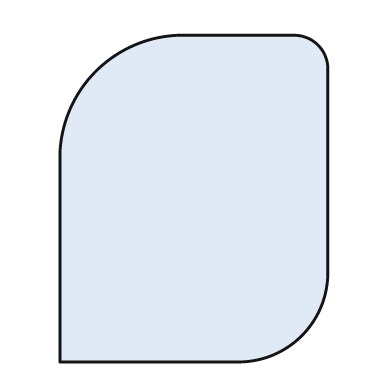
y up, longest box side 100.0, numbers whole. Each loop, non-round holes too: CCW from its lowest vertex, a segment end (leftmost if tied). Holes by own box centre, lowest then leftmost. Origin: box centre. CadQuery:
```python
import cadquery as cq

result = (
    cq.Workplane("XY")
    .moveTo(-41.0, -50.0)
    .lineTo(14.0, -50.0)
    .threePointArc((33.0, -42.0), (41.0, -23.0))
    .lineTo(41.0, 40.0)
    .threePointArc((38.0, 47.0), (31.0, 50.0))
    .lineTo(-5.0, 50.0)
    .threePointArc((-30.0, 39.0), (-41.0, 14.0))
    .close()
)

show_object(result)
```